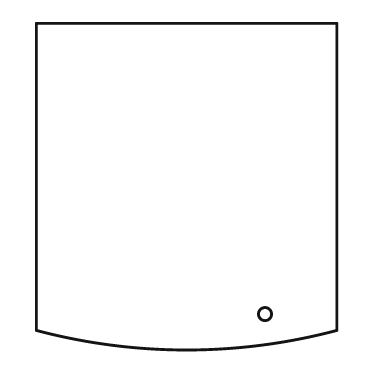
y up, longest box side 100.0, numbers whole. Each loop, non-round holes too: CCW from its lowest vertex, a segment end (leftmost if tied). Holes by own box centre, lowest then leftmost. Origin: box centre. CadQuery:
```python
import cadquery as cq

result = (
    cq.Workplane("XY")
    .moveTo(-46.0, -44.0)
    .threePointArc((0.0, -50.0), (46.0, -44.0))
    .lineTo(46.0, 50.0)
    .lineTo(-46.0, 50.0)
    .close()
    .moveTo(24.0, -39.0)
    .circle(2.0)
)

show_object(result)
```